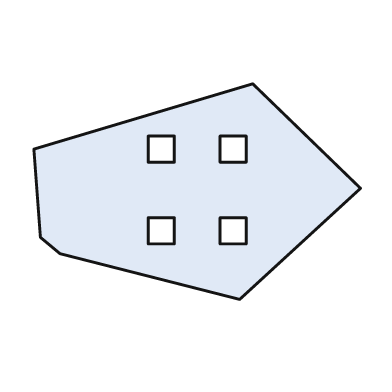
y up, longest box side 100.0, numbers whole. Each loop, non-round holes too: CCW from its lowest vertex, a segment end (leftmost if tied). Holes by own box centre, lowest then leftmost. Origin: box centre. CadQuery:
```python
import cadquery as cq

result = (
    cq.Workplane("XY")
    .moveTo(13.0, -33.0)
    .lineTo(50.0, 1.0)
    .lineTo(17.0, 33.0)
    .lineTo(-50.0, 13.0)
    .lineTo(-48.0, -14.0)
    .lineTo(-42.0, -19.0)
    .close()
    .moveTo(-15.0, -16.0)
    .lineTo(-7.0, -16.0)
    .lineTo(-7.0, -8.0)
    .lineTo(-15.0, -8.0)
    .close()
    .moveTo(7.0, -16.0)
    .lineTo(15.0, -16.0)
    .lineTo(15.0, -8.0)
    .lineTo(7.0, -8.0)
    .close()
    .moveTo(-15.0, 9.0)
    .lineTo(-7.0, 9.0)
    .lineTo(-7.0, 17.0)
    .lineTo(-15.0, 17.0)
    .close()
    .moveTo(7.0, 9.0)
    .lineTo(15.0, 9.0)
    .lineTo(15.0, 17.0)
    .lineTo(7.0, 17.0)
    .close()
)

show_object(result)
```